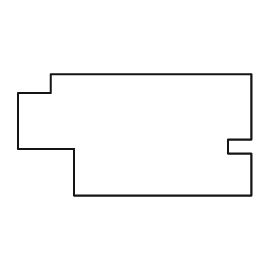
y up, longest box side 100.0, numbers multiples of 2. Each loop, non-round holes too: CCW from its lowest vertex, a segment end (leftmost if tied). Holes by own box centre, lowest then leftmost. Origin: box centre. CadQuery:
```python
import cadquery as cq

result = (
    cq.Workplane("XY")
    .moveTo(-26.0, -26.0)
    .lineTo(50.0, -26.0)
    .lineTo(50.0, -8.0)
    .lineTo(40.0, -8.0)
    .lineTo(40.0, -2.0)
    .lineTo(50.0, -2.0)
    .lineTo(50.0, 26.0)
    .lineTo(-36.0, 26.0)
    .lineTo(-36.0, 18.0)
    .lineTo(-50.0, 18.0)
    .lineTo(-50.0, -6.0)
    .lineTo(-26.0, -6.0)
    .close()
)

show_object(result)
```